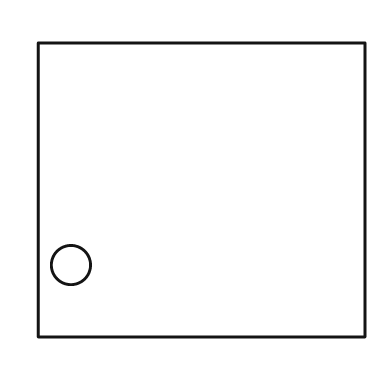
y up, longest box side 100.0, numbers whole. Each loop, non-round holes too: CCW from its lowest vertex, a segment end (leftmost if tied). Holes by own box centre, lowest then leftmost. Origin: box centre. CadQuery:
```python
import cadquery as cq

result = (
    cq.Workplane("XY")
    .moveTo(-50.0, -45.0)
    .lineTo(50.0, -45.0)
    .lineTo(50.0, 45.0)
    .lineTo(-50.0, 45.0)
    .close()
    .moveTo(-40.0, -23.0)
    .circle(6.0)
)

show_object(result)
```